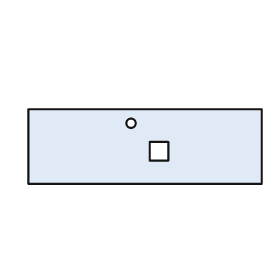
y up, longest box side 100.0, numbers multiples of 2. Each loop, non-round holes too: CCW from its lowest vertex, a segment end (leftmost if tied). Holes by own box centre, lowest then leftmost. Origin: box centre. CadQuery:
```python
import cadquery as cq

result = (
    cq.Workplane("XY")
    .moveTo(-50.0, -16.0)
    .lineTo(50.0, -16.0)
    .lineTo(50.0, 16.0)
    .lineTo(-50.0, 16.0)
    .close()
    .moveTo(2.0, -6.0)
    .lineTo(10.0, -6.0)
    .lineTo(10.0, 2.0)
    .lineTo(2.0, 2.0)
    .close()
    .moveTo(-6.0, 10.0)
    .circle(2.0)
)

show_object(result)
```